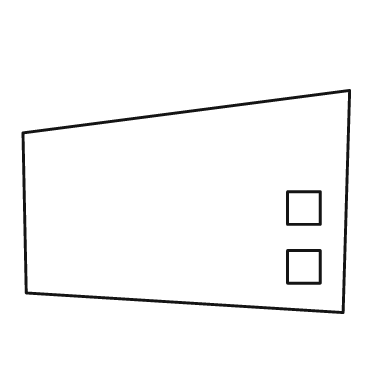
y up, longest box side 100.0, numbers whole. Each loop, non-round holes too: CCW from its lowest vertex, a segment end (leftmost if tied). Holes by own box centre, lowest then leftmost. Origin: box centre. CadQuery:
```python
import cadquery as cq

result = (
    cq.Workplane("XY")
    .moveTo(48.0, -34.0)
    .lineTo(50.0, 34.0)
    .lineTo(-50.0, 21.0)
    .lineTo(-49.0, -28.0)
    .close()
    .moveTo(31.0, -25.0)
    .lineTo(41.0, -25.0)
    .lineTo(41.0, -15.0)
    .lineTo(31.0, -15.0)
    .close()
    .moveTo(31.0, -7.0)
    .lineTo(41.0, -7.0)
    .lineTo(41.0, 3.0)
    .lineTo(31.0, 3.0)
    .close()
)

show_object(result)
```